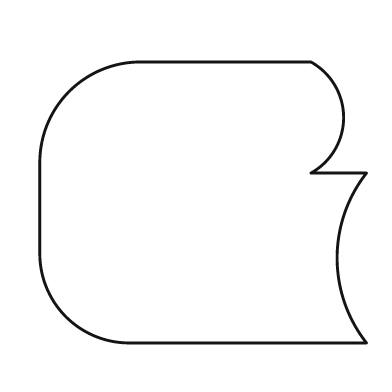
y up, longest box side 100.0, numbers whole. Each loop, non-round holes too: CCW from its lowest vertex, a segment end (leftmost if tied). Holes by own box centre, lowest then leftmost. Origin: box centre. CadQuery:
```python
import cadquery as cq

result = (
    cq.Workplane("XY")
    .moveTo(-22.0, -43.0)
    .lineTo(50.0, -43.0)
    .threePointArc((41.0, -17.0), (50.0, 9.0))
    .lineTo(33.0, 9.0)
    .threePointArc((43.0, 26.0), (33.0, 43.0))
    .lineTo(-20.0, 43.0)
    .threePointArc((-41.0, 34.0), (-50.0, 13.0))
    .lineTo(-50.0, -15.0)
    .threePointArc((-42.0, -35.0), (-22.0, -43.0))
    .close()
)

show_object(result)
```